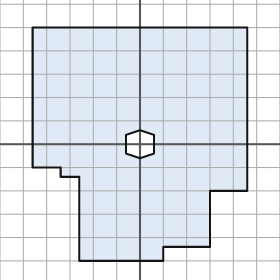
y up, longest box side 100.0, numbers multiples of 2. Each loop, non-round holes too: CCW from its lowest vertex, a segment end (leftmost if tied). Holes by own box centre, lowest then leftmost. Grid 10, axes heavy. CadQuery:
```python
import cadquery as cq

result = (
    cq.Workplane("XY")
    .moveTo(-26.0, -50.0)
    .lineTo(10.0, -50.0)
    .lineTo(10.0, -44.0)
    .lineTo(30.0, -44.0)
    .lineTo(30.0, -20.0)
    .lineTo(46.0, -20.0)
    .lineTo(46.0, 50.0)
    .lineTo(-46.0, 50.0)
    .lineTo(-46.0, -10.0)
    .lineTo(-34.0, -10.0)
    .lineTo(-34.0, -14.0)
    .lineTo(-26.0, -14.0)
    .close()
    .moveTo(0.0, -6.0)
    .lineTo(6.0, -4.0)
    .lineTo(6.0, 4.0)
    .lineTo(0.0, 6.0)
    .lineTo(-6.0, 4.0)
    .lineTo(-6.0, -4.0)
    .close()
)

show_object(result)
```